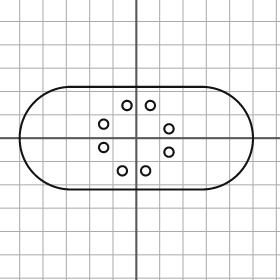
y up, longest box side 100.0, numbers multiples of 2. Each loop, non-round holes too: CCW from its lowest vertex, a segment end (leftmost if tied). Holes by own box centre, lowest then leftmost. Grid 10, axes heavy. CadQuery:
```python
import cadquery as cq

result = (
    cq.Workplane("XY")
    .moveTo(-28.0, -22.0)
    .lineTo(28.0, -22.0)
    .threePointArc((50.0, 0.0), (28.0, 22.0))
    .lineTo(-28.0, 22.0)
    .threePointArc((-50.0, 0.0), (-28.0, -22.0))
    .close()
    .moveTo(-6.0, -14.0)
    .circle(2.0)
    .moveTo(4.0, -14.0)
    .circle(2.0)
    .moveTo(14.0, -6.0)
    .circle(2.0)
    .moveTo(-14.0, -4.0)
    .circle(2.0)
    .moveTo(14.0, 4.0)
    .circle(2.0)
    .moveTo(-14.0, 6.0)
    .circle(2.0)
    .moveTo(-4.0, 14.0)
    .circle(2.0)
    .moveTo(6.0, 14.0)
    .circle(2.0)
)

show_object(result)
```